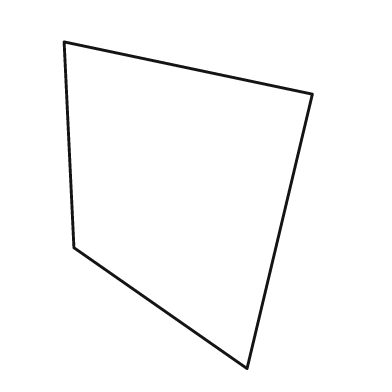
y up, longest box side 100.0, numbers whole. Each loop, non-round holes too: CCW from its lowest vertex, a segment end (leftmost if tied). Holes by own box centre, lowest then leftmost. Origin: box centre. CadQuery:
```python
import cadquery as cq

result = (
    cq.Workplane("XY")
    .moveTo(18.0, -50.0)
    .lineTo(38.0, 34.0)
    .lineTo(-38.0, 50.0)
    .lineTo(-35.0, -13.0)
    .close()
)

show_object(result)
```